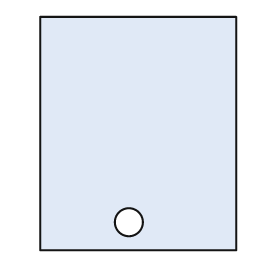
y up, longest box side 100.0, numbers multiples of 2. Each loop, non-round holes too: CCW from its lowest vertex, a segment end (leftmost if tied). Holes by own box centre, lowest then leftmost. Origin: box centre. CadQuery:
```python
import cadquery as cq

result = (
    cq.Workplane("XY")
    .moveTo(-42.0, -50.0)
    .lineTo(42.0, -50.0)
    .lineTo(42.0, 50.0)
    .lineTo(-42.0, 50.0)
    .close()
    .moveTo(-4.0, -38.0)
    .circle(6.0)
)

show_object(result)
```